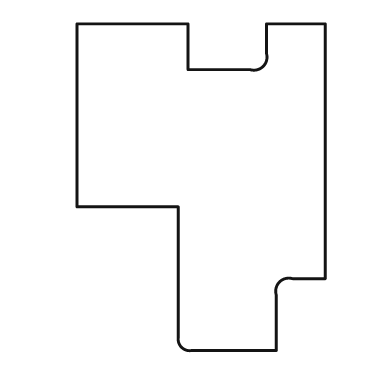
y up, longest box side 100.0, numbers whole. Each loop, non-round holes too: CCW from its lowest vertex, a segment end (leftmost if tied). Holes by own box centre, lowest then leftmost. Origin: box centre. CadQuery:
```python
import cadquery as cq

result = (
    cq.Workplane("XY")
    .moveTo(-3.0, -50.0)
    .lineTo(23.0, -50.0)
    .lineTo(23.0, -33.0)
    .threePointArc((24.0, -29.0), (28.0, -28.0))
    .lineTo(38.0, -28.0)
    .lineTo(38.0, 50.0)
    .lineTo(20.0, 50.0)
    .lineTo(20.0, 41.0)
    .threePointArc((19.0, 37.0), (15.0, 36.0))
    .lineTo(-4.0, 36.0)
    .lineTo(-4.0, 50.0)
    .lineTo(-38.0, 50.0)
    .lineTo(-38.0, -6.0)
    .lineTo(-7.0, -6.0)
    .lineTo(-7.0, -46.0)
    .threePointArc((-6.0, -49.0), (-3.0, -50.0))
    .close()
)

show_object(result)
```